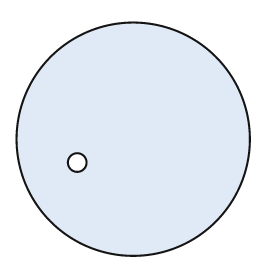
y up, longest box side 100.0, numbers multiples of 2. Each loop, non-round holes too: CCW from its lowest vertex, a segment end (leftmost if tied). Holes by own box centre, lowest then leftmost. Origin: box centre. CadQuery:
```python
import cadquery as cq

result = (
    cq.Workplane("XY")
    .moveTo(0.0, 0.0)
    .circle(50.0)
    .moveTo(-24.0, -10.0)
    .circle(4.0)
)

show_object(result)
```